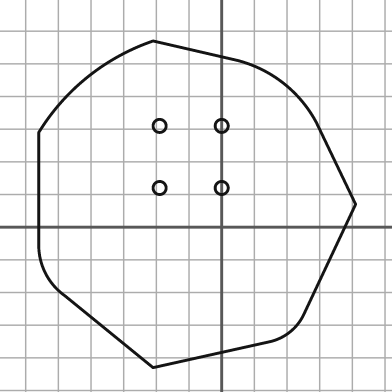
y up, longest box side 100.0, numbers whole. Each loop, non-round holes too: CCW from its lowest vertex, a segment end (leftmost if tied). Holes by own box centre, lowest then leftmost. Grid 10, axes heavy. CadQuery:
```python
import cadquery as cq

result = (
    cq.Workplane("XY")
    .moveTo(-21.0, -43.0)
    .lineTo(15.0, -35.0)
    .threePointArc((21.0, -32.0), (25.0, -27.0))
    .lineTo(41.0, 7.0)
    .lineTo(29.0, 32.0)
    .threePointArc((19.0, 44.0), (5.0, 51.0))
    .lineTo(-21.0, 57.0)
    .threePointArc((-41.0, 46.0), (-56.0, 29.0))
    .lineTo(-56.0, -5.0)
    .threePointArc((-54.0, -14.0), (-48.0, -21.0))
    .close()
    .moveTo(-19.0, 12.0)
    .circle(2.0)
    .moveTo(0.0, 12.0)
    .circle(2.0)
    .moveTo(-19.0, 31.0)
    .circle(2.0)
    .moveTo(0.0, 31.0)
    .circle(2.0)
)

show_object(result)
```